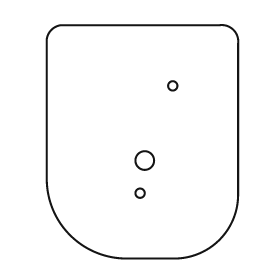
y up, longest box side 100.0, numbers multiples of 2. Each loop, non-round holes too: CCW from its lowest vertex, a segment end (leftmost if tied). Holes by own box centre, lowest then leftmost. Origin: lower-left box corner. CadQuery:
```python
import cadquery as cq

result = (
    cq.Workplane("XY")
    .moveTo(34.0, 0.0)
    .lineTo(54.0, 0.0)
    .threePointArc((74.0, 8.0), (82.0, 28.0))
    .lineTo(82.0, 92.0)
    .threePointArc((80.0, 98.0), (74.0, 100.0))
    .lineTo(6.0, 100.0)
    .threePointArc((2.0, 98.0), (0.0, 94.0))
    .lineTo(0.0, 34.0)
    .threePointArc((10.0, 10.0), (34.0, 0.0))
    .close()
    .moveTo(40.0, 28.0)
    .circle(2.0)
    .moveTo(42.0, 42.0)
    .circle(4.0)
    .moveTo(54.0, 74.0)
    .circle(2.0)
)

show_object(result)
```